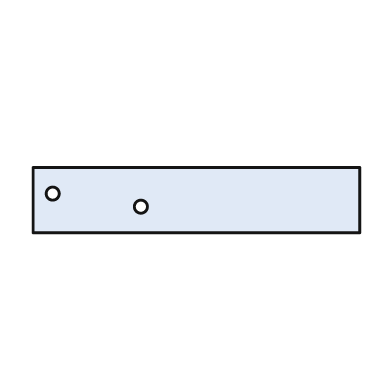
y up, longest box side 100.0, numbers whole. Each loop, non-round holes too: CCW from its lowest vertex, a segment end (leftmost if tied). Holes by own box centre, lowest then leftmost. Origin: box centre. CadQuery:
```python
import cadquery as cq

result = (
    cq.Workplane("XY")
    .moveTo(-50.0, -10.0)
    .lineTo(50.0, -10.0)
    .lineTo(50.0, 10.0)
    .lineTo(-50.0, 10.0)
    .close()
    .moveTo(-17.0, -2.0)
    .circle(2.0)
    .moveTo(-44.0, 2.0)
    .circle(2.0)
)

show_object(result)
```